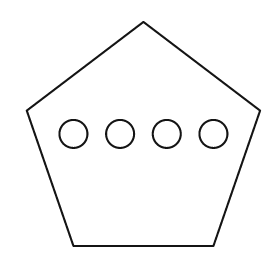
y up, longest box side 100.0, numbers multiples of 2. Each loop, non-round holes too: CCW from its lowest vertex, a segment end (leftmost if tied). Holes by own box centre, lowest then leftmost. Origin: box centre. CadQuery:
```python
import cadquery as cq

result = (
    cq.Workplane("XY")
    .moveTo(-30.0, -48.0)
    .lineTo(30.0, -48.0)
    .lineTo(50.0, 10.0)
    .lineTo(0.0, 48.0)
    .lineTo(-50.0, 10.0)
    .close()
    .moveTo(-30.0, 0.0)
    .circle(6.0)
    .moveTo(-10.0, 0.0)
    .circle(6.0)
    .moveTo(10.0, 0.0)
    .circle(6.0)
    .moveTo(30.0, 0.0)
    .circle(6.0)
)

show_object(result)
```